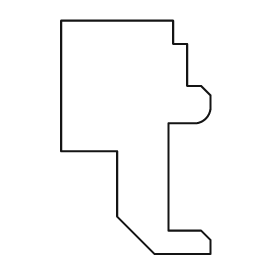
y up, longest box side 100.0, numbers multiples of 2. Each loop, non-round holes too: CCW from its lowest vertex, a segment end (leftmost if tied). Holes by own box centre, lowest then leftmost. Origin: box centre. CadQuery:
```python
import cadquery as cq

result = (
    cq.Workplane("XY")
    .moveTo(8.0, -50.0)
    .lineTo(32.0, -50.0)
    .lineTo(32.0, -44.0)
    .lineTo(28.0, -40.0)
    .lineTo(14.0, -40.0)
    .lineTo(14.0, 6.0)
    .lineTo(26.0, 6.0)
    .threePointArc((30.0, 8.0), (32.0, 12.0))
    .lineTo(32.0, 18.0)
    .lineTo(28.0, 22.0)
    .lineTo(22.0, 22.0)
    .lineTo(22.0, 40.0)
    .lineTo(16.0, 40.0)
    .lineTo(16.0, 50.0)
    .lineTo(-32.0, 50.0)
    .lineTo(-32.0, -6.0)
    .lineTo(-8.0, -6.0)
    .lineTo(-8.0, -34.0)
    .close()
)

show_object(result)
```